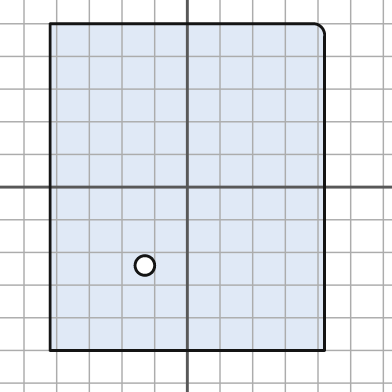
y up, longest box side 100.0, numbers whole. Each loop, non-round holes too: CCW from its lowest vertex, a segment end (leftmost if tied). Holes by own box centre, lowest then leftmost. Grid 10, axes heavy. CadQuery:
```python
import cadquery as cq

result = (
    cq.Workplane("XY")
    .moveTo(-42.0, -50.0)
    .lineTo(42.0, -50.0)
    .lineTo(42.0, 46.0)
    .threePointArc((41.0, 49.0), (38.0, 50.0))
    .lineTo(-42.0, 50.0)
    .close()
    .moveTo(-13.0, -24.0)
    .circle(3.0)
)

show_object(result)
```